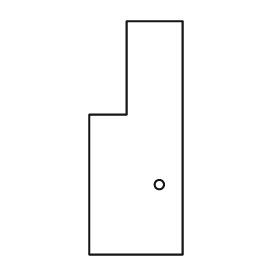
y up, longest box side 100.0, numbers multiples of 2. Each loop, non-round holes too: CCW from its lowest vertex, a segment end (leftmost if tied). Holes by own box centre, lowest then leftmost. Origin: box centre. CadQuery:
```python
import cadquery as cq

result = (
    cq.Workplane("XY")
    .moveTo(-20.0, -50.0)
    .lineTo(20.0, -50.0)
    .lineTo(20.0, 50.0)
    .lineTo(-4.0, 50.0)
    .lineTo(-4.0, 10.0)
    .lineTo(-20.0, 10.0)
    .close()
    .moveTo(10.0, -20.0)
    .circle(2.0)
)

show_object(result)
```